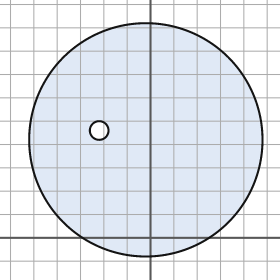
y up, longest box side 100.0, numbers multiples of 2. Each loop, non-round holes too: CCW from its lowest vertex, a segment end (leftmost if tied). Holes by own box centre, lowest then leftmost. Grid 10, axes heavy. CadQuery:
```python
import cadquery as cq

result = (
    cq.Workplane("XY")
    .moveTo(-2.0, 42.0)
    .circle(50.0)
    .moveTo(-22.0, 46.0)
    .circle(4.0)
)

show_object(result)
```